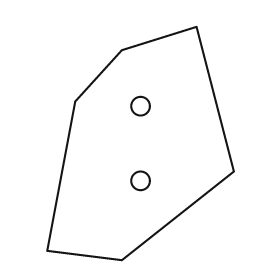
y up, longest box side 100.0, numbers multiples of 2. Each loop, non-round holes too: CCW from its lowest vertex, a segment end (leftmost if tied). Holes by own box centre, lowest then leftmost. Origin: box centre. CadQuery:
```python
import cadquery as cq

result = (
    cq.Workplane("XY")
    .moveTo(-8.0, -50.0)
    .lineTo(40.0, -12.0)
    .lineTo(24.0, 50.0)
    .lineTo(-8.0, 40.0)
    .lineTo(-28.0, 18.0)
    .lineTo(-40.0, -46.0)
    .close()
    .moveTo(0.0, -16.0)
    .circle(4.0)
    .moveTo(0.0, 16.0)
    .circle(4.0)
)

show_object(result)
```